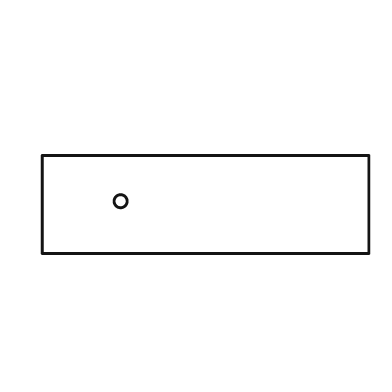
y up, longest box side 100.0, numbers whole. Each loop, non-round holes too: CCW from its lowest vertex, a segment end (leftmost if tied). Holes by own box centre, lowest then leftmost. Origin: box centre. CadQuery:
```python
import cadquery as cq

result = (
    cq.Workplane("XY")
    .moveTo(-50.0, -15.0)
    .lineTo(50.0, -15.0)
    .lineTo(50.0, 15.0)
    .lineTo(-50.0, 15.0)
    .close()
    .moveTo(-26.0, 1.0)
    .circle(2.0)
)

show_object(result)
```